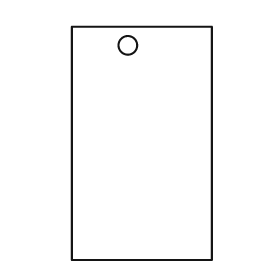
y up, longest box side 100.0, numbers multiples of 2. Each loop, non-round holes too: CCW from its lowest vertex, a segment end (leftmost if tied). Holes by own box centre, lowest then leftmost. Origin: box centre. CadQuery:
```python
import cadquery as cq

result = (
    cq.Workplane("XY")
    .moveTo(-30.0, -50.0)
    .lineTo(30.0, -50.0)
    .lineTo(30.0, 50.0)
    .lineTo(-30.0, 50.0)
    .close()
    .moveTo(-6.0, 42.0)
    .circle(4.0)
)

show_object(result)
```